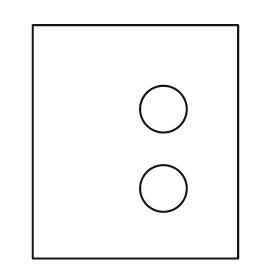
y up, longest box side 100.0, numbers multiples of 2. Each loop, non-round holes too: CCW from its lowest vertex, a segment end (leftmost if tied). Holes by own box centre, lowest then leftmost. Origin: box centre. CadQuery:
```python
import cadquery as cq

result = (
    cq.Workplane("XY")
    .moveTo(-44.0, -50.0)
    .lineTo(44.0, -50.0)
    .lineTo(44.0, 50.0)
    .lineTo(-44.0, 50.0)
    .close()
    .moveTo(12.0, -20.0)
    .circle(10.0)
    .moveTo(12.0, 14.0)
    .circle(10.0)
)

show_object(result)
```